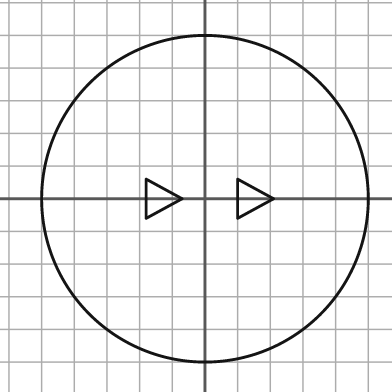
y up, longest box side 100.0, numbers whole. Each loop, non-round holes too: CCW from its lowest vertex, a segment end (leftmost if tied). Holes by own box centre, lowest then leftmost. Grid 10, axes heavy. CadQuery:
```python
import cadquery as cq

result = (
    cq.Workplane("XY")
    .moveTo(0.0, 0.0)
    .circle(50.0)
    .moveTo(-18.0, -6.0)
    .lineTo(-7.0, 0.0)
    .lineTo(-18.0, 6.0)
    .close()
    .moveTo(10.0, -6.0)
    .lineTo(21.0, 0.0)
    .lineTo(10.0, 6.0)
    .close()
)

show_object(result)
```